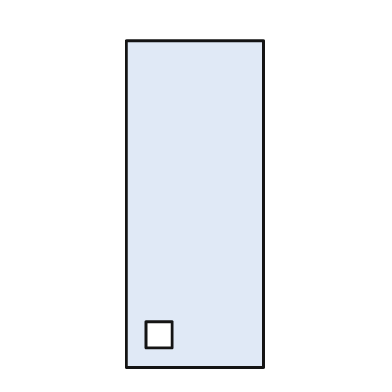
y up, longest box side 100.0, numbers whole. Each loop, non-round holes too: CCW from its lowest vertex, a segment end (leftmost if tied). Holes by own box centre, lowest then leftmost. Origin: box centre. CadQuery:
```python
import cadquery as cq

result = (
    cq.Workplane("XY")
    .moveTo(-21.0, -50.0)
    .lineTo(21.0, -50.0)
    .lineTo(21.0, 50.0)
    .lineTo(-21.0, 50.0)
    .close()
    .moveTo(-15.0, -44.0)
    .lineTo(-7.0, -44.0)
    .lineTo(-7.0, -36.0)
    .lineTo(-15.0, -36.0)
    .close()
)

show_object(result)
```